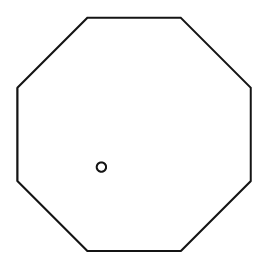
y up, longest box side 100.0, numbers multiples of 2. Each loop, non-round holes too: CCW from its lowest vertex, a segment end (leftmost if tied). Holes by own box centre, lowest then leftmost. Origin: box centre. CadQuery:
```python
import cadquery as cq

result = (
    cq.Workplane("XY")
    .moveTo(-20.0, -50.0)
    .lineTo(20.0, -50.0)
    .lineTo(50.0, -20.0)
    .lineTo(50.0, 20.0)
    .lineTo(20.0, 50.0)
    .lineTo(-20.0, 50.0)
    .lineTo(-50.0, 20.0)
    .lineTo(-50.0, -20.0)
    .close()
    .moveTo(-14.0, -14.0)
    .circle(2.0)
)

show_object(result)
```